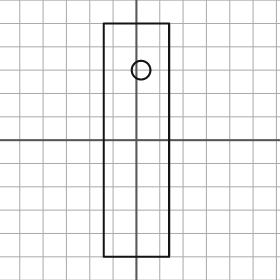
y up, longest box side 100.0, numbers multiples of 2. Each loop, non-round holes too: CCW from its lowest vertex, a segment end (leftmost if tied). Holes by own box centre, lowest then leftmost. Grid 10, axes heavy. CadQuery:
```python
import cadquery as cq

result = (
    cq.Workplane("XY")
    .moveTo(-14.0, -50.0)
    .lineTo(14.0, -50.0)
    .lineTo(14.0, 50.0)
    .lineTo(-14.0, 50.0)
    .close()
    .moveTo(2.0, 30.0)
    .circle(4.0)
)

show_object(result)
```